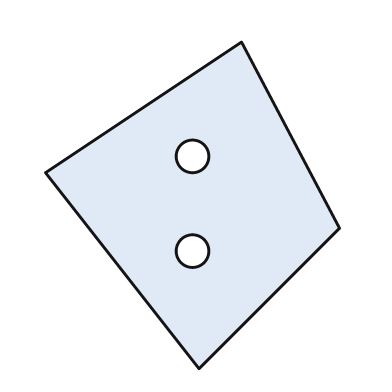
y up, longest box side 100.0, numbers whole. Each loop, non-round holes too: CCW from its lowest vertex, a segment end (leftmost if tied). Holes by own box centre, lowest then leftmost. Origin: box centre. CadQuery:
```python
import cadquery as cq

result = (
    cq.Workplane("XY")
    .moveTo(2.0, -50.0)
    .lineTo(45.0, -7.0)
    .lineTo(15.0, 50.0)
    .lineTo(-45.0, 10.0)
    .close()
    .moveTo(0.0, -14.0)
    .circle(5.0)
    .moveTo(0.0, 15.0)
    .circle(5.0)
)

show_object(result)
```